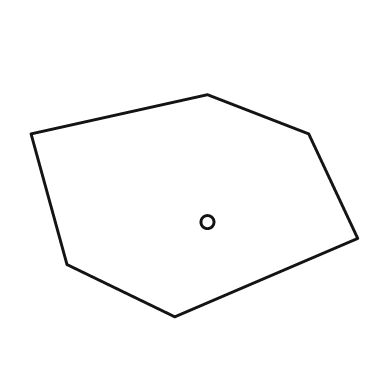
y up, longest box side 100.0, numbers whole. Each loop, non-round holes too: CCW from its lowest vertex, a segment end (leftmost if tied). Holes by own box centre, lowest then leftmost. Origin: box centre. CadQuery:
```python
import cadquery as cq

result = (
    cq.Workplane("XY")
    .moveTo(-6.0, -34.0)
    .lineTo(50.0, -10.0)
    .lineTo(35.0, 22.0)
    .lineTo(4.0, 34.0)
    .lineTo(-50.0, 22.0)
    .lineTo(-39.0, -18.0)
    .close()
    .moveTo(4.0, -5.0)
    .circle(2.0)
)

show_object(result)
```